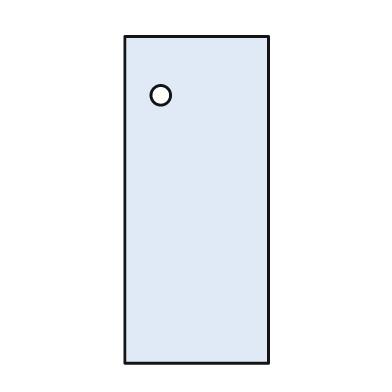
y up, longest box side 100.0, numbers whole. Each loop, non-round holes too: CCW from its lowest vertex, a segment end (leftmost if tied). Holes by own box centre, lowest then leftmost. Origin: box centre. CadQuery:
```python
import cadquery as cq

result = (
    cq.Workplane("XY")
    .moveTo(-22.0, -50.0)
    .lineTo(22.0, -50.0)
    .lineTo(22.0, 50.0)
    .lineTo(-22.0, 50.0)
    .close()
    .moveTo(-11.0, 32.0)
    .circle(3.0)
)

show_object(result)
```